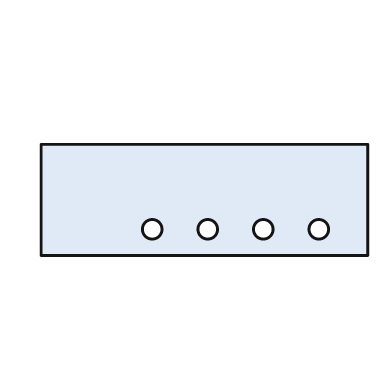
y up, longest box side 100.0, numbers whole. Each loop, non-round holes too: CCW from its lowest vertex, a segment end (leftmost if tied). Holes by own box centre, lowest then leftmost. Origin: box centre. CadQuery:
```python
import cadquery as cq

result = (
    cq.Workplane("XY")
    .moveTo(-50.0, -17.0)
    .lineTo(50.0, -17.0)
    .lineTo(50.0, 17.0)
    .lineTo(-50.0, 17.0)
    .close()
    .moveTo(-16.0, -9.0)
    .circle(3.0)
    .moveTo(1.0, -9.0)
    .circle(3.0)
    .moveTo(18.0, -9.0)
    .circle(3.0)
    .moveTo(35.0, -9.0)
    .circle(3.0)
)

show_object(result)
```